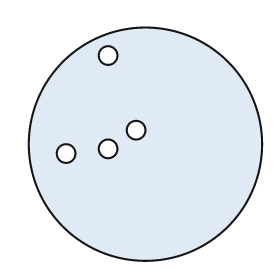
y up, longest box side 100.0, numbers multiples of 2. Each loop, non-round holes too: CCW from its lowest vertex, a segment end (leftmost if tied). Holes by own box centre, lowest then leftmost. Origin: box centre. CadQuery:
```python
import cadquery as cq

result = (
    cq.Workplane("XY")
    .moveTo(0.0, 0.0)
    .circle(50.0)
    .moveTo(-34.0, -4.0)
    .circle(4.0)
    .moveTo(-16.0, -2.0)
    .circle(4.0)
    .moveTo(-4.0, 6.0)
    .circle(4.0)
    .moveTo(-16.0, 38.0)
    .circle(4.0)
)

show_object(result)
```